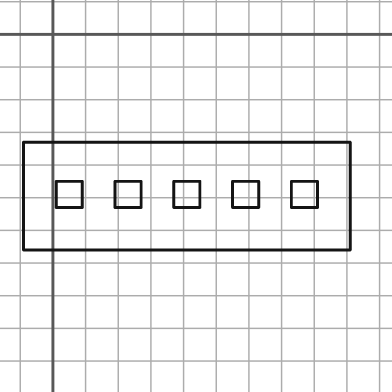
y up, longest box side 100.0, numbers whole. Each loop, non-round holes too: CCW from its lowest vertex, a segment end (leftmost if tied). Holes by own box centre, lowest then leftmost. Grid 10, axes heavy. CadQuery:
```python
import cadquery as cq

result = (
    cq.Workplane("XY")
    .moveTo(-9.0, -66.0)
    .lineTo(91.0, -66.0)
    .lineTo(91.0, -33.0)
    .lineTo(-9.0, -33.0)
    .close()
    .moveTo(1.0, -53.0)
    .lineTo(9.0, -53.0)
    .lineTo(9.0, -45.0)
    .lineTo(1.0, -45.0)
    .close()
    .moveTo(19.0, -53.0)
    .lineTo(27.0, -53.0)
    .lineTo(27.0, -45.0)
    .lineTo(19.0, -45.0)
    .close()
    .moveTo(37.0, -53.0)
    .lineTo(45.0, -53.0)
    .lineTo(45.0, -45.0)
    .lineTo(37.0, -45.0)
    .close()
    .moveTo(55.0, -53.0)
    .lineTo(63.0, -53.0)
    .lineTo(63.0, -45.0)
    .lineTo(55.0, -45.0)
    .close()
    .moveTo(73.0, -53.0)
    .lineTo(81.0, -53.0)
    .lineTo(81.0, -45.0)
    .lineTo(73.0, -45.0)
    .close()
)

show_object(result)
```